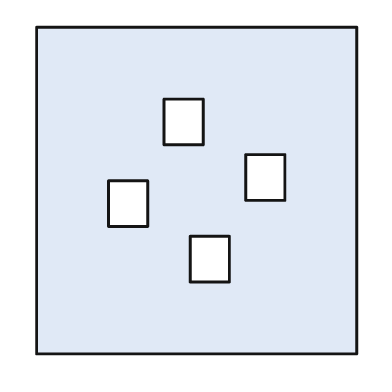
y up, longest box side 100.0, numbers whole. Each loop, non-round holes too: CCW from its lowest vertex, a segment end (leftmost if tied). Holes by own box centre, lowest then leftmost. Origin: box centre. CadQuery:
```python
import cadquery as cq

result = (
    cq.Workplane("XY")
    .moveTo(-49.0, -50.0)
    .lineTo(49.0, -50.0)
    .lineTo(49.0, 50.0)
    .lineTo(-49.0, 50.0)
    .close()
    .moveTo(-2.0, -28.0)
    .lineTo(10.0, -28.0)
    .lineTo(10.0, -14.0)
    .lineTo(-2.0, -14.0)
    .close()
    .moveTo(-27.0, -11.0)
    .lineTo(-15.0, -11.0)
    .lineTo(-15.0, 3.0)
    .lineTo(-27.0, 3.0)
    .close()
    .moveTo(15.0, -3.0)
    .lineTo(27.0, -3.0)
    .lineTo(27.0, 11.0)
    .lineTo(15.0, 11.0)
    .close()
    .moveTo(-10.0, 14.0)
    .lineTo(2.0, 14.0)
    .lineTo(2.0, 28.0)
    .lineTo(-10.0, 28.0)
    .close()
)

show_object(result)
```